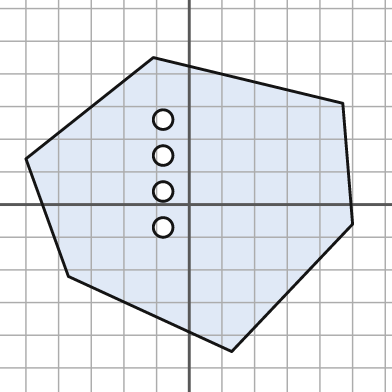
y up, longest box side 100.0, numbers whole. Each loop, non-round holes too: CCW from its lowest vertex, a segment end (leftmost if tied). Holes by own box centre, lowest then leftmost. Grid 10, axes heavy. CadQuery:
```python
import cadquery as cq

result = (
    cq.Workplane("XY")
    .moveTo(13.0, -45.0)
    .lineTo(50.0, -6.0)
    .lineTo(47.0, 31.0)
    .lineTo(-11.0, 45.0)
    .lineTo(-50.0, 14.0)
    .lineTo(-37.0, -22.0)
    .close()
    .moveTo(-8.0, -7.0)
    .circle(3.0)
    .moveTo(-8.0, 4.0)
    .circle(3.0)
    .moveTo(-8.0, 15.0)
    .circle(3.0)
    .moveTo(-8.0, 26.0)
    .circle(3.0)
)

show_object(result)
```